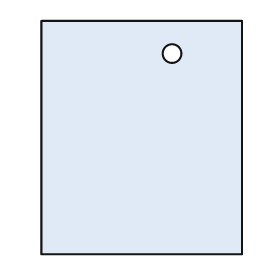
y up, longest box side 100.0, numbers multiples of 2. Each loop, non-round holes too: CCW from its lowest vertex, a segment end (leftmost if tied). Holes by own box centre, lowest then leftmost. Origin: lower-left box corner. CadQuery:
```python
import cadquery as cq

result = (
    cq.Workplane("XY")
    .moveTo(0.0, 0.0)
    .lineTo(86.0, 0.0)
    .lineTo(86.0, 100.0)
    .lineTo(0.0, 100.0)
    .close()
    .moveTo(56.0, 86.0)
    .circle(4.0)
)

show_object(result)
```